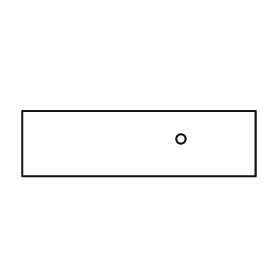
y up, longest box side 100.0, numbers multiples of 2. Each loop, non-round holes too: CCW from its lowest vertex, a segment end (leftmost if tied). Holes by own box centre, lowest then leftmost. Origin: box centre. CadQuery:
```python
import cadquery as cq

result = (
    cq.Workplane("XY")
    .moveTo(-50.0, -14.0)
    .lineTo(50.0, -14.0)
    .lineTo(50.0, 14.0)
    .lineTo(-50.0, 14.0)
    .close()
    .moveTo(18.0, 2.0)
    .circle(2.0)
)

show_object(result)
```